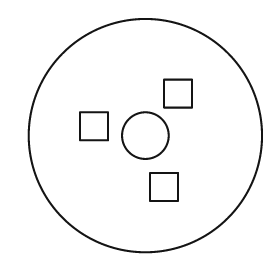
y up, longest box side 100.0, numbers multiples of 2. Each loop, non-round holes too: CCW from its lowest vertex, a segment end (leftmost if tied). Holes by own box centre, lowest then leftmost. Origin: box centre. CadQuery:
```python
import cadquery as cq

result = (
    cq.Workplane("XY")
    .moveTo(0.0, 0.0)
    .circle(50.0)
    .moveTo(2.0, -28.0)
    .lineTo(14.0, -28.0)
    .lineTo(14.0, -16.0)
    .lineTo(2.0, -16.0)
    .close()
    .moveTo(0.0, 0.0)
    .circle(10.0)
    .moveTo(-28.0, -2.0)
    .lineTo(-16.0, -2.0)
    .lineTo(-16.0, 10.0)
    .lineTo(-28.0, 10.0)
    .close()
    .moveTo(8.0, 12.0)
    .lineTo(20.0, 12.0)
    .lineTo(20.0, 24.0)
    .lineTo(8.0, 24.0)
    .close()
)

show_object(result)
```